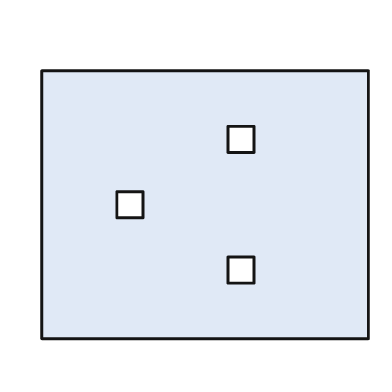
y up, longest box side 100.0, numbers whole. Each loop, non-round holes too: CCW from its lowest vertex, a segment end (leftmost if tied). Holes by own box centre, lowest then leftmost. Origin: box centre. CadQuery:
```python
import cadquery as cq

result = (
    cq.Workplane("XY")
    .moveTo(-50.0, -41.0)
    .lineTo(50.0, -41.0)
    .lineTo(50.0, 41.0)
    .lineTo(-50.0, 41.0)
    .close()
    .moveTo(7.0, -24.0)
    .lineTo(15.0, -24.0)
    .lineTo(15.0, -16.0)
    .lineTo(7.0, -16.0)
    .close()
    .moveTo(-27.0, -4.0)
    .lineTo(-19.0, -4.0)
    .lineTo(-19.0, 4.0)
    .lineTo(-27.0, 4.0)
    .close()
    .moveTo(7.0, 16.0)
    .lineTo(15.0, 16.0)
    .lineTo(15.0, 24.0)
    .lineTo(7.0, 24.0)
    .close()
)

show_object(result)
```